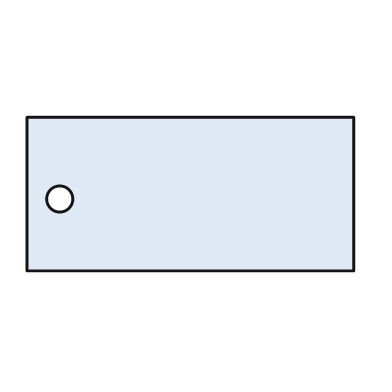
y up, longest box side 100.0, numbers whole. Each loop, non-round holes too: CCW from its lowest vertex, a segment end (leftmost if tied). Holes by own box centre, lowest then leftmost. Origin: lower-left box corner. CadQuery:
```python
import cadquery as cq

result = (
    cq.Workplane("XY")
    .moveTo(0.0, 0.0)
    .lineTo(100.0, 0.0)
    .lineTo(100.0, 47.0)
    .lineTo(0.0, 47.0)
    .close()
    .moveTo(10.0, 22.0)
    .circle(4.0)
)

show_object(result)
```